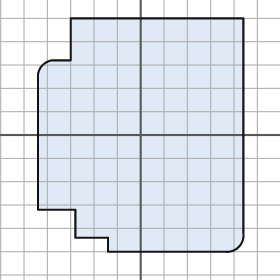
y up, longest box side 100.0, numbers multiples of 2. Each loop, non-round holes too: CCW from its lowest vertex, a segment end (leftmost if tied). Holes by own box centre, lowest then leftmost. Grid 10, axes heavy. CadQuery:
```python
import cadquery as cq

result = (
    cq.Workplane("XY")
    .moveTo(-14.0, -50.0)
    .lineTo(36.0, -50.0)
    .threePointArc((42.0, -48.0), (44.0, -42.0))
    .lineTo(44.0, 50.0)
    .lineTo(-30.0, 50.0)
    .lineTo(-30.0, 32.0)
    .lineTo(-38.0, 32.0)
    .threePointArc((-42.0, 30.0), (-44.0, 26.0))
    .lineTo(-44.0, -32.0)
    .lineTo(-28.0, -32.0)
    .lineTo(-28.0, -44.0)
    .lineTo(-14.0, -44.0)
    .close()
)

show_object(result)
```